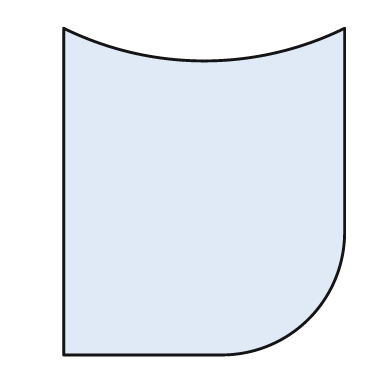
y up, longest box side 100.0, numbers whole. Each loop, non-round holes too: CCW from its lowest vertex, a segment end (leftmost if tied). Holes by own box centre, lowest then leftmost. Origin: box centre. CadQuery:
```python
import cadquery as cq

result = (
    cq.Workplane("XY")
    .moveTo(-43.0, -50.0)
    .lineTo(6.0, -50.0)
    .threePointArc((32.0, -39.0), (43.0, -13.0))
    .lineTo(43.0, 50.0)
    .threePointArc((0.0, 40.0), (-43.0, 50.0))
    .close()
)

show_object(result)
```